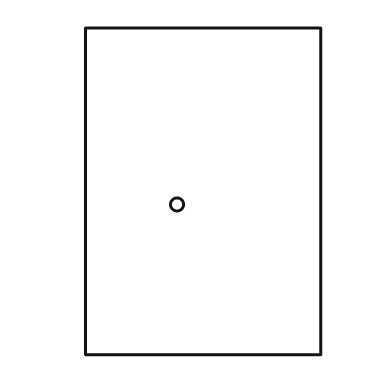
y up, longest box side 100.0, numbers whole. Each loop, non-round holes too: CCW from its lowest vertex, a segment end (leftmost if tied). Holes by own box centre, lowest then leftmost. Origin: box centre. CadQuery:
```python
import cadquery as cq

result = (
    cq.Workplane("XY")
    .moveTo(-36.0, -50.0)
    .lineTo(36.0, -50.0)
    .lineTo(36.0, 50.0)
    .lineTo(-36.0, 50.0)
    .close()
    .moveTo(-8.0, -4.0)
    .circle(2.0)
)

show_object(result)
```